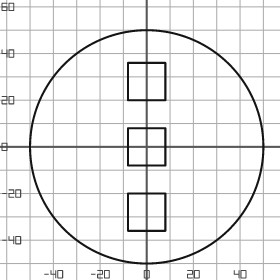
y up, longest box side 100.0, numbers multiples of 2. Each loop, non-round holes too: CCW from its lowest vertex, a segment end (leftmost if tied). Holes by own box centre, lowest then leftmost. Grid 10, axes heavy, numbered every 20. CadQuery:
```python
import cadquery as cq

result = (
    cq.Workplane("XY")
    .moveTo(0.0, 0.0)
    .circle(50.0)
    .moveTo(-8.0, -36.0)
    .lineTo(8.0, -36.0)
    .lineTo(8.0, -20.0)
    .lineTo(-8.0, -20.0)
    .close()
    .moveTo(-8.0, -8.0)
    .lineTo(8.0, -8.0)
    .lineTo(8.0, 8.0)
    .lineTo(-8.0, 8.0)
    .close()
    .moveTo(-8.0, 20.0)
    .lineTo(8.0, 20.0)
    .lineTo(8.0, 36.0)
    .lineTo(-8.0, 36.0)
    .close()
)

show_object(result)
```